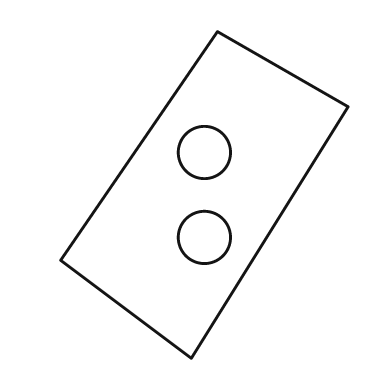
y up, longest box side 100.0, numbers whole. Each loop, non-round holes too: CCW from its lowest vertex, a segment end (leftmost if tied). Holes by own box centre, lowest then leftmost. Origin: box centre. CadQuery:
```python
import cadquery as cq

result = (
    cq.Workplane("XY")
    .moveTo(-4.0, -50.0)
    .lineTo(44.0, 27.0)
    .lineTo(4.0, 50.0)
    .lineTo(-44.0, -20.0)
    .close()
    .moveTo(0.0, -13.0)
    .circle(8.0)
    .moveTo(0.0, 13.0)
    .circle(8.0)
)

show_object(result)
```